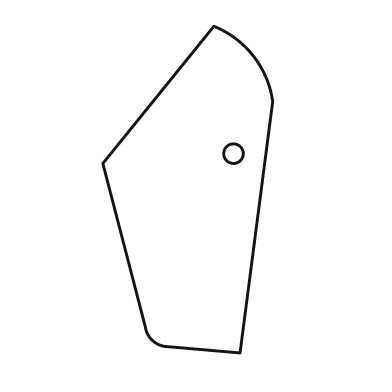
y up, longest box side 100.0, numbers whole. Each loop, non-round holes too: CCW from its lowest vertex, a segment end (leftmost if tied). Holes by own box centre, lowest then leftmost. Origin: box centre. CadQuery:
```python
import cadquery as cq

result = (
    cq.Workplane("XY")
    .moveTo(16.0, -50.0)
    .lineTo(26.0, 27.0)
    .threePointArc((20.0, 41.0), (8.0, 50.0))
    .lineTo(-26.0, 8.0)
    .lineTo(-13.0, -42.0)
    .threePointArc((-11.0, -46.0), (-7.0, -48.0))
    .close()
    .moveTo(14.0, 11.0)
    .circle(3.0)
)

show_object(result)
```